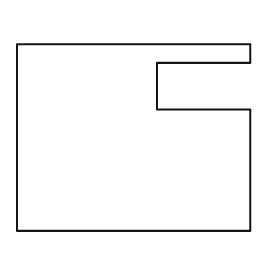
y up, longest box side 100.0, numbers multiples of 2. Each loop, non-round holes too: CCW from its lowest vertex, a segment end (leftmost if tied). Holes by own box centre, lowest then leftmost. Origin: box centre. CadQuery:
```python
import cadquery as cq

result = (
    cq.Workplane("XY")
    .moveTo(-50.0, -40.0)
    .lineTo(50.0, -40.0)
    .lineTo(50.0, 12.0)
    .lineTo(10.0, 12.0)
    .lineTo(10.0, 32.0)
    .lineTo(50.0, 32.0)
    .lineTo(50.0, 40.0)
    .lineTo(-50.0, 40.0)
    .close()
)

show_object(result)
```